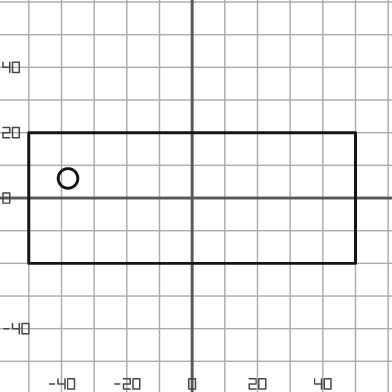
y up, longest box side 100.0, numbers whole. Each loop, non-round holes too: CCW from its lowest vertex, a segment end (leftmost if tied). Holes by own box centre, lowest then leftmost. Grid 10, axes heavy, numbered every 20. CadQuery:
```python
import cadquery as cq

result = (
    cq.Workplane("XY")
    .moveTo(-50.0, -20.0)
    .lineTo(50.0, -20.0)
    .lineTo(50.0, 20.0)
    .lineTo(-50.0, 20.0)
    .close()
    .moveTo(-38.0, 6.0)
    .circle(3.0)
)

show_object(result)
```